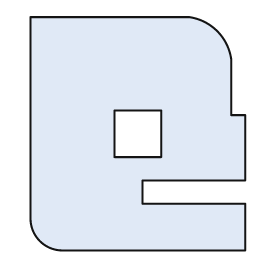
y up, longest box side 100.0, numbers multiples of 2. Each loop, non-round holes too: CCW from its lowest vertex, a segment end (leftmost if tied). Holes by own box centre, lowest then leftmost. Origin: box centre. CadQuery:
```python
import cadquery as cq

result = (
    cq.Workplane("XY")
    .moveTo(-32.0, -50.0)
    .lineTo(46.0, -50.0)
    .lineTo(46.0, -30.0)
    .lineTo(2.0, -30.0)
    .lineTo(2.0, -20.0)
    .lineTo(46.0, -20.0)
    .lineTo(46.0, 8.0)
    .lineTo(40.0, 8.0)
    .lineTo(40.0, 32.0)
    .threePointArc((34.0, 44.0), (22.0, 50.0))
    .lineTo(-46.0, 50.0)
    .lineTo(-46.0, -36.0)
    .threePointArc((-42.0, -46.0), (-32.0, -50.0))
    .close()
    .moveTo(-10.0, -10.0)
    .lineTo(10.0, -10.0)
    .lineTo(10.0, 10.0)
    .lineTo(-10.0, 10.0)
    .close()
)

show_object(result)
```